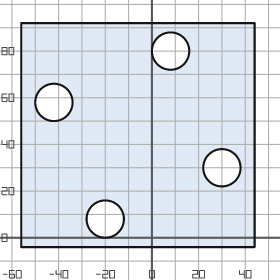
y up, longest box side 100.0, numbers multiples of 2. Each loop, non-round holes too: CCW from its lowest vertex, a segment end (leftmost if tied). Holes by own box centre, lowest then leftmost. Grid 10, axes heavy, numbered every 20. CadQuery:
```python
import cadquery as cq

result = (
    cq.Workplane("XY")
    .moveTo(-56.0, -4.0)
    .lineTo(44.0, -4.0)
    .lineTo(44.0, 92.0)
    .lineTo(-56.0, 92.0)
    .close()
    .moveTo(-20.0, 8.0)
    .circle(8.0)
    .moveTo(30.0, 30.0)
    .circle(8.0)
    .moveTo(-42.0, 58.0)
    .circle(8.0)
    .moveTo(8.0, 80.0)
    .circle(8.0)
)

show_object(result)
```